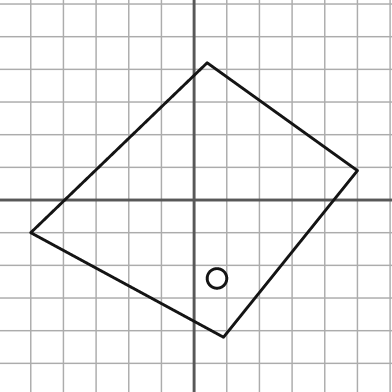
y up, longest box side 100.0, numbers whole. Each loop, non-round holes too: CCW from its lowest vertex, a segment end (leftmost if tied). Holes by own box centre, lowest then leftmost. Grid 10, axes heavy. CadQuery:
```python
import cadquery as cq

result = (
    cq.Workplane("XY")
    .moveTo(9.0, -42.0)
    .lineTo(50.0, 9.0)
    .lineTo(4.0, 42.0)
    .lineTo(-50.0, -10.0)
    .close()
    .moveTo(7.0, -24.0)
    .circle(3.0)
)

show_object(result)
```